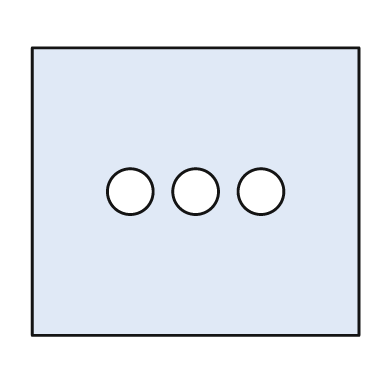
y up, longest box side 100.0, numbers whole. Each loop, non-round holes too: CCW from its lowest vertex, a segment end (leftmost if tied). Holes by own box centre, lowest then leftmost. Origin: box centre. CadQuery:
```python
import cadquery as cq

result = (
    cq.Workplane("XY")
    .moveTo(-50.0, -44.0)
    .lineTo(50.0, -44.0)
    .lineTo(50.0, 44.0)
    .lineTo(-50.0, 44.0)
    .close()
    .moveTo(-20.0, 0.0)
    .circle(7.0)
    .moveTo(0.0, 0.0)
    .circle(7.0)
    .moveTo(20.0, 0.0)
    .circle(7.0)
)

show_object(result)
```